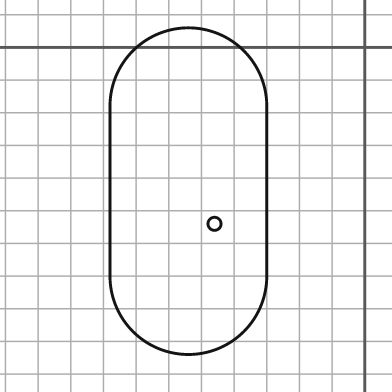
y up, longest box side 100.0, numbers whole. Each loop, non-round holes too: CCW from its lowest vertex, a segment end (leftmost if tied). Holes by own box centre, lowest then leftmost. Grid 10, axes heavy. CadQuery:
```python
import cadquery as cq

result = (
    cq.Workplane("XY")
    .moveTo(-78.0, -70.0)
    .threePointArc((-54.0, -94.0), (-30.0, -70.0))
    .lineTo(-30.0, -18.0)
    .threePointArc((-54.0, 6.0), (-78.0, -18.0))
    .close()
    .moveTo(-46.0, -54.0)
    .circle(2.0)
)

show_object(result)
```